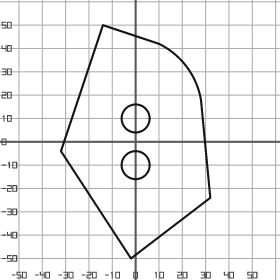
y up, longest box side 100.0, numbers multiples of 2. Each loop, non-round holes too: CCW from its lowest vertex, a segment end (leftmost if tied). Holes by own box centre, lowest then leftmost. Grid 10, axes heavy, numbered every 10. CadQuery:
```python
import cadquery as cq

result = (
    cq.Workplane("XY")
    .moveTo(-2.0, -50.0)
    .lineTo(32.0, -24.0)
    .lineTo(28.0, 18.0)
    .threePointArc((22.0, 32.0), (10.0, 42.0))
    .lineTo(-14.0, 50.0)
    .lineTo(-32.0, -4.0)
    .close()
    .moveTo(0.0, -10.0)
    .circle(6.0)
    .moveTo(0.0, 10.0)
    .circle(6.0)
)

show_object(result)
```